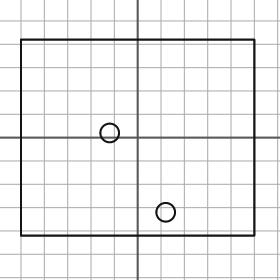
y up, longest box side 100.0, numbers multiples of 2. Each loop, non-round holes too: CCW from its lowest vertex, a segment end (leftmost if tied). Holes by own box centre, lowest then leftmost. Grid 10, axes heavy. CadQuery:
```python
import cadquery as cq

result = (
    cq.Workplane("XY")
    .moveTo(-50.0, -42.0)
    .lineTo(50.0, -42.0)
    .lineTo(50.0, 42.0)
    .lineTo(-50.0, 42.0)
    .close()
    .moveTo(12.0, -32.0)
    .circle(4.0)
    .moveTo(-12.0, 2.0)
    .circle(4.0)
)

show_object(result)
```